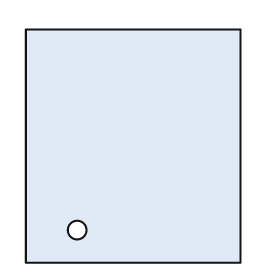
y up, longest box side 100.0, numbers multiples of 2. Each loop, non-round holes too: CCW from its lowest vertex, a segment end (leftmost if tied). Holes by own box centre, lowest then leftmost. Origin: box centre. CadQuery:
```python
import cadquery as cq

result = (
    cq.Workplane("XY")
    .moveTo(-46.0, -50.0)
    .lineTo(46.0, -50.0)
    .lineTo(46.0, 50.0)
    .lineTo(-46.0, 50.0)
    .close()
    .moveTo(-24.0, -36.0)
    .circle(4.0)
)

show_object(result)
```